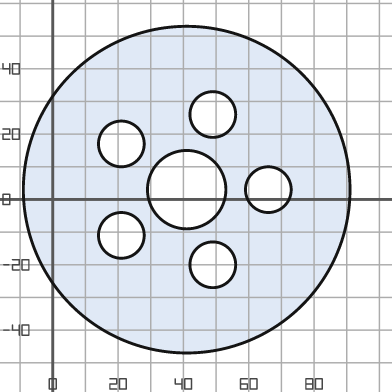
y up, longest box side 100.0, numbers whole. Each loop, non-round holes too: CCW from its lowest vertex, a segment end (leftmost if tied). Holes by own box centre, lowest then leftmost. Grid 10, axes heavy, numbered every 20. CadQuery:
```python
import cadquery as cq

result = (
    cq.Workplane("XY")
    .moveTo(41.0, 3.0)
    .circle(50.0)
    .moveTo(49.0, -20.0)
    .circle(7.0)
    .moveTo(21.0, -11.0)
    .circle(7.0)
    .moveTo(41.0, 3.0)
    .circle(12.0)
    .moveTo(66.0, 3.0)
    .circle(7.0)
    .moveTo(21.0, 17.0)
    .circle(7.0)
    .moveTo(49.0, 26.0)
    .circle(7.0)
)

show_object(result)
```